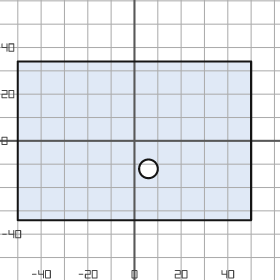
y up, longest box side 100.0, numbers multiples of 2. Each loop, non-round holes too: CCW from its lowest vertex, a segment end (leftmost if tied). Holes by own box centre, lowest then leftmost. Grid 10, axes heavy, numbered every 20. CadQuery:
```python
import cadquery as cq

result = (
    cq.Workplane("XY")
    .moveTo(-50.0, -34.0)
    .lineTo(50.0, -34.0)
    .lineTo(50.0, 34.0)
    .lineTo(-50.0, 34.0)
    .close()
    .moveTo(6.0, -12.0)
    .circle(4.0)
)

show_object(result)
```